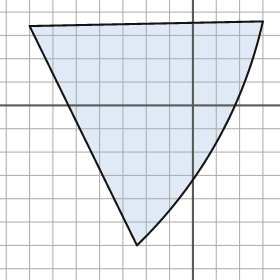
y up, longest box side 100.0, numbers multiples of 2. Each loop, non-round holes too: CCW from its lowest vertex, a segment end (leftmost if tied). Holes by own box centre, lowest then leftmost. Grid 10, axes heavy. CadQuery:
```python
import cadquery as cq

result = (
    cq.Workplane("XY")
    .moveTo(-24.0, -60.0)
    .threePointArc((10.0, -16.0), (30.0, 36.0))
    .lineTo(-70.0, 34.0)
    .close()
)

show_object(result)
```